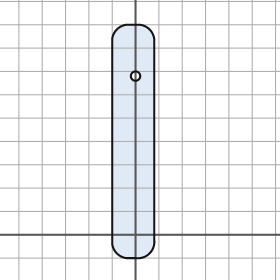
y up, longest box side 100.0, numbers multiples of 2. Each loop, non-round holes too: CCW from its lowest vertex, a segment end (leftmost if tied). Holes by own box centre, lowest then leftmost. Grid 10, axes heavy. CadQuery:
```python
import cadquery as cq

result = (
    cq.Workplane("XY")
    .moveTo(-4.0, -10.0)
    .lineTo(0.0, -10.0)
    .threePointArc((6.0, -8.0), (8.0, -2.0))
    .lineTo(8.0, 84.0)
    .threePointArc((6.0, 88.0), (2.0, 90.0))
    .lineTo(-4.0, 90.0)
    .threePointArc((-8.0, 88.0), (-10.0, 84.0))
    .lineTo(-10.0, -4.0)
    .threePointArc((-8.0, -8.0), (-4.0, -10.0))
    .close()
    .moveTo(0.0, 68.0)
    .circle(2.0)
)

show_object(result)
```